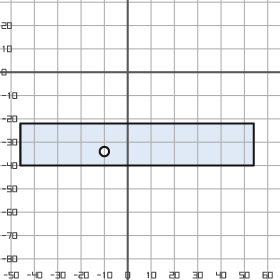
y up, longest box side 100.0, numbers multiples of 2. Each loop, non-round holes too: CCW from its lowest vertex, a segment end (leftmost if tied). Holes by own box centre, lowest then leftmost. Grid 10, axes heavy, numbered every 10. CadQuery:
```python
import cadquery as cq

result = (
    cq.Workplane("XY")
    .moveTo(-46.0, -40.0)
    .lineTo(54.0, -40.0)
    .lineTo(54.0, -22.0)
    .lineTo(-46.0, -22.0)
    .close()
    .moveTo(-10.0, -34.0)
    .circle(2.0)
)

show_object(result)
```